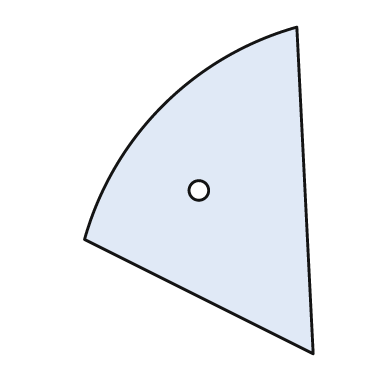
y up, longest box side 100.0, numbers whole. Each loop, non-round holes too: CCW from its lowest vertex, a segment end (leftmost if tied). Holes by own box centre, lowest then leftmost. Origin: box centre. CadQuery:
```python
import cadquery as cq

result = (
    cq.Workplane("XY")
    .moveTo(35.0, -50.0)
    .lineTo(30.0, 50.0)
    .threePointArc((-11.0, 26.0), (-35.0, -15.0))
    .close()
    .moveTo(0.0, 0.0)
    .circle(3.0)
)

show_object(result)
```